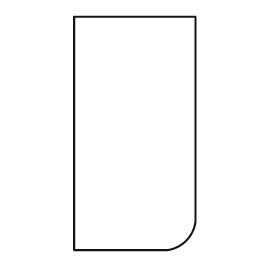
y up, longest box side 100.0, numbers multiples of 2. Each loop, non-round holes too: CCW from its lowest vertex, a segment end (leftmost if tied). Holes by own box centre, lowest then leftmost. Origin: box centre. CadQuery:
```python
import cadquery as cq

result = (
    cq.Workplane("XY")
    .moveTo(-26.0, -50.0)
    .lineTo(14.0, -50.0)
    .threePointArc((22.0, -46.0), (26.0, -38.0))
    .lineTo(26.0, 50.0)
    .lineTo(-26.0, 50.0)
    .close()
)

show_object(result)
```